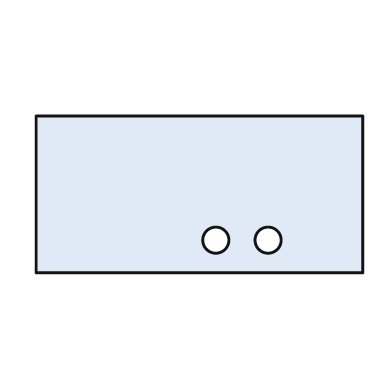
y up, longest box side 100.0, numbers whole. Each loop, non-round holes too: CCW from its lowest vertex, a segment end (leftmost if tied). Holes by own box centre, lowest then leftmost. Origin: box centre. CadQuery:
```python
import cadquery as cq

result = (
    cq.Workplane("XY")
    .moveTo(-50.0, -24.0)
    .lineTo(50.0, -24.0)
    .lineTo(50.0, 24.0)
    .lineTo(-50.0, 24.0)
    .close()
    .moveTo(5.0, -14.0)
    .circle(4.0)
    .moveTo(21.0, -14.0)
    .circle(4.0)
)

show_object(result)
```